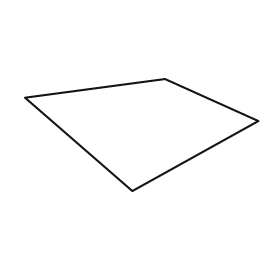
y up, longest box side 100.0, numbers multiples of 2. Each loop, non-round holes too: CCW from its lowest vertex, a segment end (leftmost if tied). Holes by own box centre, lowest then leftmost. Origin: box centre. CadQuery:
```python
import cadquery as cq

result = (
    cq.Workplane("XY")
    .moveTo(-4.0, -24.0)
    .lineTo(50.0, 6.0)
    .lineTo(10.0, 24.0)
    .lineTo(-50.0, 16.0)
    .close()
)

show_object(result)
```